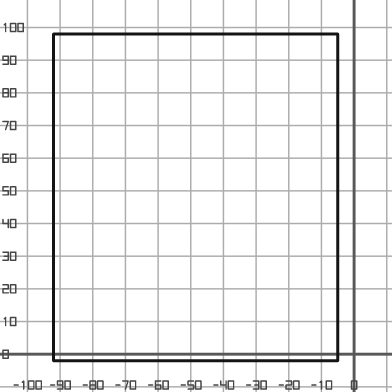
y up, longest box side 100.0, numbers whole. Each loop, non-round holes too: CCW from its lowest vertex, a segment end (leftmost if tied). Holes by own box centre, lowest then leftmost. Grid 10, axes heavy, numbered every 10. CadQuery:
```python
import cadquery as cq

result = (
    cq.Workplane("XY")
    .moveTo(-92.0, -2.0)
    .lineTo(-5.0, -2.0)
    .lineTo(-5.0, 98.0)
    .lineTo(-92.0, 98.0)
    .close()
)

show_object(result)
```